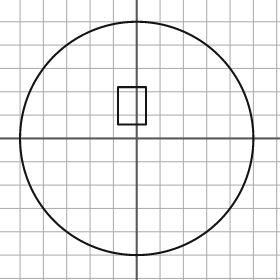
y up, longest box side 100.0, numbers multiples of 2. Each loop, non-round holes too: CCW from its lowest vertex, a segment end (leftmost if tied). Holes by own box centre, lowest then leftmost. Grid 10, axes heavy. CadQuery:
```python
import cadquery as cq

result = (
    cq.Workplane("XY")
    .moveTo(0.0, 0.0)
    .circle(50.0)
    .moveTo(-8.0, 6.0)
    .lineTo(4.0, 6.0)
    .lineTo(4.0, 22.0)
    .lineTo(-8.0, 22.0)
    .close()
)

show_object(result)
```